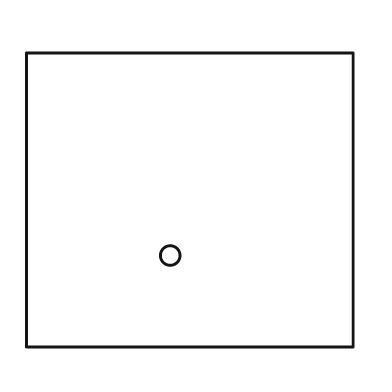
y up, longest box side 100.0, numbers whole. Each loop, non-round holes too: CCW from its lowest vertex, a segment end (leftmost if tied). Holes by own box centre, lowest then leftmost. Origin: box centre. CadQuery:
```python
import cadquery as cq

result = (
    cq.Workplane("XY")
    .moveTo(-50.0, -45.0)
    .lineTo(50.0, -45.0)
    .lineTo(50.0, 45.0)
    .lineTo(-50.0, 45.0)
    .close()
    .moveTo(-6.0, -17.0)
    .circle(3.0)
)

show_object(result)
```